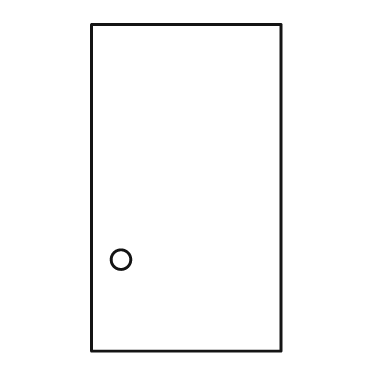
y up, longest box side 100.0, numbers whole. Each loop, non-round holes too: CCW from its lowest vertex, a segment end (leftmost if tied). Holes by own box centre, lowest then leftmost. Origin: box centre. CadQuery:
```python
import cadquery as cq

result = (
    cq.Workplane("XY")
    .moveTo(-29.0, -50.0)
    .lineTo(29.0, -50.0)
    .lineTo(29.0, 50.0)
    .lineTo(-29.0, 50.0)
    .close()
    .moveTo(-20.0, -22.0)
    .circle(3.0)
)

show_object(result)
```